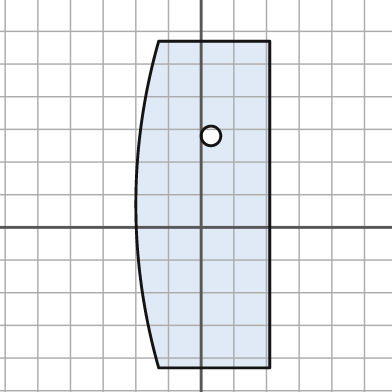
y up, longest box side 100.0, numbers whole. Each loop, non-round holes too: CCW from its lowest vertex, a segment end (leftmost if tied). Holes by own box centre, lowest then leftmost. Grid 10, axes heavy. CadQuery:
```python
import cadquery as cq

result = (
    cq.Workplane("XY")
    .moveTo(-13.0, -43.0)
    .lineTo(21.0, -43.0)
    .lineTo(21.0, 57.0)
    .lineTo(-13.0, 57.0)
    .threePointArc((-20.0, 7.0), (-13.0, -43.0))
    .close()
    .moveTo(3.0, 28.0)
    .circle(3.0)
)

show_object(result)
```